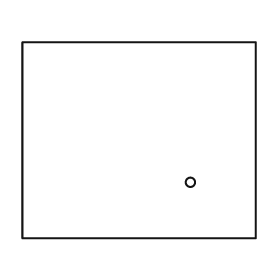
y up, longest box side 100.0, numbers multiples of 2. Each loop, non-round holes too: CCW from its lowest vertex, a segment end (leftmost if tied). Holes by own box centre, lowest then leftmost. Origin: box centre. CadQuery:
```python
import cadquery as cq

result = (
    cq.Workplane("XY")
    .moveTo(-50.0, -42.0)
    .lineTo(50.0, -42.0)
    .lineTo(50.0, 42.0)
    .lineTo(-50.0, 42.0)
    .close()
    .moveTo(22.0, -18.0)
    .circle(2.0)
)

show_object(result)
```